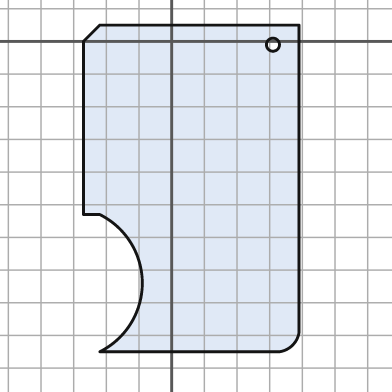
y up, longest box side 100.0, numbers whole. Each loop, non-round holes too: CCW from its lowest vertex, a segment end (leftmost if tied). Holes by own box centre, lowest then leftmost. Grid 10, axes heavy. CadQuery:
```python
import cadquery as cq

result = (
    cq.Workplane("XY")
    .moveTo(-22.0, -95.0)
    .lineTo(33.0, -95.0)
    .threePointArc((37.0, -93.0), (39.0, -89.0))
    .lineTo(39.0, 5.0)
    .lineTo(-22.0, 5.0)
    .lineTo(-27.0, 0.0)
    .lineTo(-27.0, -53.0)
    .lineTo(-22.0, -53.0)
    .threePointArc((-9.0, -74.0), (-22.0, -95.0))
    .close()
    .moveTo(31.0, -1.0)
    .circle(2.0)
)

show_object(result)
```